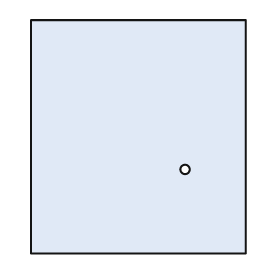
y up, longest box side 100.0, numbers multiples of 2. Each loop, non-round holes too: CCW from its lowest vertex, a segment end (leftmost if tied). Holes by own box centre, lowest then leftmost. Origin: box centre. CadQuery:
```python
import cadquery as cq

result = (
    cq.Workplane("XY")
    .moveTo(-46.0, -50.0)
    .lineTo(46.0, -50.0)
    .lineTo(46.0, 50.0)
    .lineTo(-46.0, 50.0)
    .close()
    .moveTo(20.0, -14.0)
    .circle(2.0)
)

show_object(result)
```